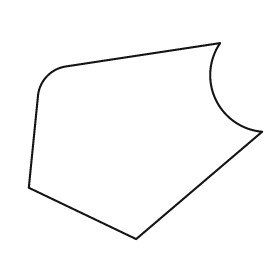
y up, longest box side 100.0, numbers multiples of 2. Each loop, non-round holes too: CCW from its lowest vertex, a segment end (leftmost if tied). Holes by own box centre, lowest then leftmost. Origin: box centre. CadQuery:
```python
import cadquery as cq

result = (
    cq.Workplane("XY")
    .moveTo(-4.0, -42.0)
    .lineTo(50.0, 4.0)
    .threePointArc((30.0, 18.0), (32.0, 42.0))
    .lineTo(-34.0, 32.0)
    .threePointArc((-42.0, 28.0), (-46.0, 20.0))
    .lineTo(-50.0, -20.0)
    .close()
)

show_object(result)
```